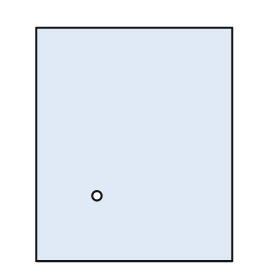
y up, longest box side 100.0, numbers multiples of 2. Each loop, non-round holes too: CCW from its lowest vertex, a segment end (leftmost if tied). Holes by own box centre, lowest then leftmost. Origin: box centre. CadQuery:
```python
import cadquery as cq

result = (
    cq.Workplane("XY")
    .moveTo(-42.0, -50.0)
    .lineTo(42.0, -50.0)
    .lineTo(42.0, 50.0)
    .lineTo(-42.0, 50.0)
    .close()
    .moveTo(-16.0, -22.0)
    .circle(2.0)
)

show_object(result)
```